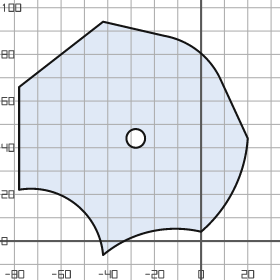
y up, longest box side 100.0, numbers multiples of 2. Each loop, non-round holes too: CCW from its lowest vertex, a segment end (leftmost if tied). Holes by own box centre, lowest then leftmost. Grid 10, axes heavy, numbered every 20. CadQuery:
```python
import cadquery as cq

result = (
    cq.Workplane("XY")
    .moveTo(-42.0, -6.0)
    .threePointArc((-22.0, 4.0), (0.0, 4.0))
    .threePointArc((14.0, 22.0), (20.0, 44.0))
    .lineTo(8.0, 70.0)
    .threePointArc((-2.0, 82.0), (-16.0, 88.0))
    .lineTo(-42.0, 94.0)
    .lineTo(-78.0, 66.0)
    .lineTo(-78.0, 22.0)
    .threePointArc((-54.0, 16.0), (-42.0, -6.0))
    .close()
    .moveTo(-28.0, 44.0)
    .circle(4.0)
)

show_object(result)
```